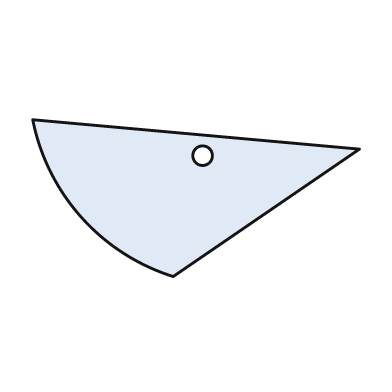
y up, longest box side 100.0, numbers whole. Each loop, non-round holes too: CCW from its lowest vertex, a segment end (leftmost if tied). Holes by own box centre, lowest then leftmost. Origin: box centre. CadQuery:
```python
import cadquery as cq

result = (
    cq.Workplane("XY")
    .moveTo(-7.0, -24.0)
    .lineTo(50.0, 15.0)
    .lineTo(-50.0, 24.0)
    .threePointArc((-35.0, -6.0), (-7.0, -24.0))
    .close()
    .moveTo(2.0, 13.0)
    .circle(3.0)
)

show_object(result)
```